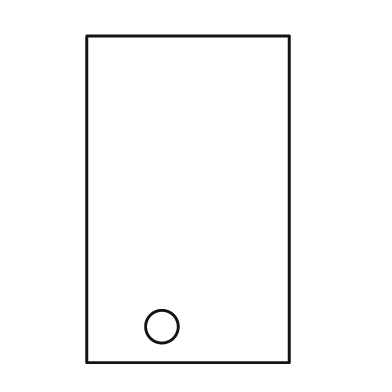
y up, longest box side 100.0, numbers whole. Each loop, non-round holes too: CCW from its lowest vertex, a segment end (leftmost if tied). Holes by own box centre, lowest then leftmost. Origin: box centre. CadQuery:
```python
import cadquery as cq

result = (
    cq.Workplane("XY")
    .moveTo(-31.0, -50.0)
    .lineTo(31.0, -50.0)
    .lineTo(31.0, 50.0)
    .lineTo(-31.0, 50.0)
    .close()
    .moveTo(-8.0, -39.0)
    .circle(5.0)
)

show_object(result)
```